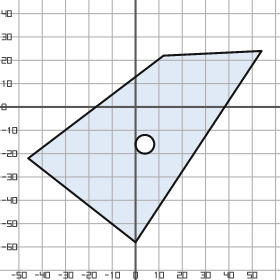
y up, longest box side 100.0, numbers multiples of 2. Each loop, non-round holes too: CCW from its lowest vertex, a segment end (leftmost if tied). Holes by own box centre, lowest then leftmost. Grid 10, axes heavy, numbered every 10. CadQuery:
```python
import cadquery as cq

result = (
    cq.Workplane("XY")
    .moveTo(0.0, -58.0)
    .lineTo(54.0, 24.0)
    .lineTo(12.0, 22.0)
    .lineTo(-46.0, -22.0)
    .close()
    .moveTo(4.0, -16.0)
    .circle(4.0)
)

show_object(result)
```